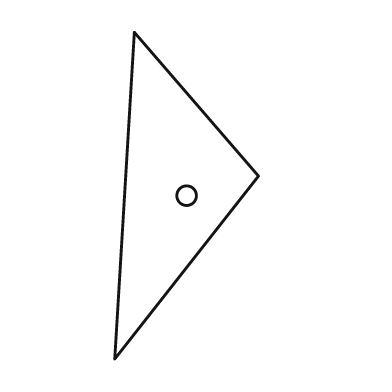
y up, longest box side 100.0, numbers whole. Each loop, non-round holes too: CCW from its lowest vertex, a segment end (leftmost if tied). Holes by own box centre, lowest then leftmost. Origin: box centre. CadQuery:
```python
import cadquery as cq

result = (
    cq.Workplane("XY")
    .moveTo(-22.0, -50.0)
    .lineTo(22.0, 6.0)
    .lineTo(-16.0, 50.0)
    .close()
    .moveTo(0.0, 0.0)
    .circle(3.0)
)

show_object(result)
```